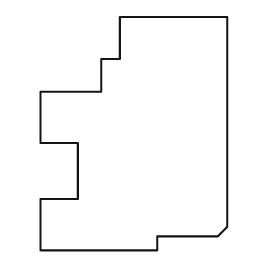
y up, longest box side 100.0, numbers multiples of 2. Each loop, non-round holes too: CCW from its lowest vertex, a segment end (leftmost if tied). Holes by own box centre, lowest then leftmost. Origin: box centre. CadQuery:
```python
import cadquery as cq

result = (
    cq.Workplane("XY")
    .moveTo(-40.0, -50.0)
    .lineTo(10.0, -50.0)
    .lineTo(10.0, -44.0)
    .lineTo(36.0, -44.0)
    .lineTo(40.0, -40.0)
    .lineTo(40.0, 50.0)
    .lineTo(-6.0, 50.0)
    .lineTo(-6.0, 32.0)
    .lineTo(-14.0, 32.0)
    .lineTo(-14.0, 18.0)
    .lineTo(-40.0, 18.0)
    .lineTo(-40.0, -4.0)
    .lineTo(-24.0, -4.0)
    .lineTo(-24.0, -28.0)
    .lineTo(-40.0, -28.0)
    .close()
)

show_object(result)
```